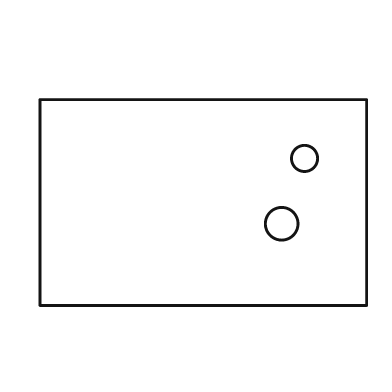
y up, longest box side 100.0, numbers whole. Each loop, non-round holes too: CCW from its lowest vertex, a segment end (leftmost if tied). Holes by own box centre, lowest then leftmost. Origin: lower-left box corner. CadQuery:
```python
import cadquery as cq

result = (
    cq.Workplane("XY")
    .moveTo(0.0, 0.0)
    .lineTo(100.0, 0.0)
    .lineTo(100.0, 63.0)
    .lineTo(0.0, 63.0)
    .close()
    .moveTo(74.0, 25.0)
    .circle(5.0)
    .moveTo(81.0, 45.0)
    .circle(4.0)
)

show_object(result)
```